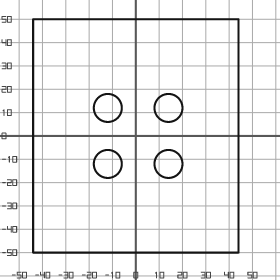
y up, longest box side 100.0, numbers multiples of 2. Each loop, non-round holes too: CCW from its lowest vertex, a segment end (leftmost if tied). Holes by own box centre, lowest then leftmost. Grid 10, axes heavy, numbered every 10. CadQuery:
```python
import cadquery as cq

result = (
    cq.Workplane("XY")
    .moveTo(-44.0, -50.0)
    .lineTo(44.0, -50.0)
    .lineTo(44.0, 50.0)
    .lineTo(-44.0, 50.0)
    .close()
    .moveTo(-12.0, -12.0)
    .circle(6.0)
    .moveTo(14.0, -12.0)
    .circle(6.0)
    .moveTo(-12.0, 12.0)
    .circle(6.0)
    .moveTo(14.0, 12.0)
    .circle(6.0)
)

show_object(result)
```